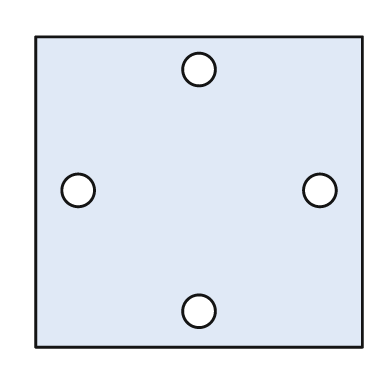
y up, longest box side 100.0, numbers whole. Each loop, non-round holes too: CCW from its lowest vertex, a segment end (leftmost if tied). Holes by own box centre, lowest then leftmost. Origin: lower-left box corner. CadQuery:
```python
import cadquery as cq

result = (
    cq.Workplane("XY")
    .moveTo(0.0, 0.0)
    .lineTo(100.0, 0.0)
    .lineTo(100.0, 95.0)
    .lineTo(0.0, 95.0)
    .close()
    .moveTo(50.0, 11.0)
    .circle(5.0)
    .moveTo(13.0, 48.0)
    .circle(5.0)
    .moveTo(87.0, 48.0)
    .circle(5.0)
    .moveTo(50.0, 85.0)
    .circle(5.0)
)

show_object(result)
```